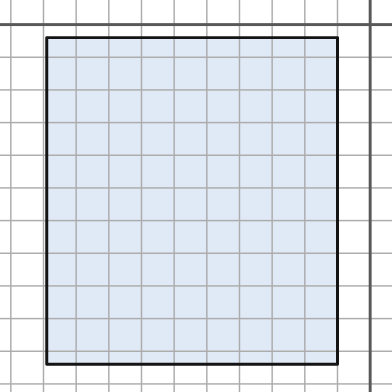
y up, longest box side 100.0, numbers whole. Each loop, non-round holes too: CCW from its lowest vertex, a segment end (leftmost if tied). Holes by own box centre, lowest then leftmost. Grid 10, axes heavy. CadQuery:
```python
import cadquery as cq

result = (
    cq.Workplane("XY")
    .moveTo(-99.0, -104.0)
    .lineTo(-10.0, -104.0)
    .lineTo(-10.0, -4.0)
    .lineTo(-99.0, -4.0)
    .close()
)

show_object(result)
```